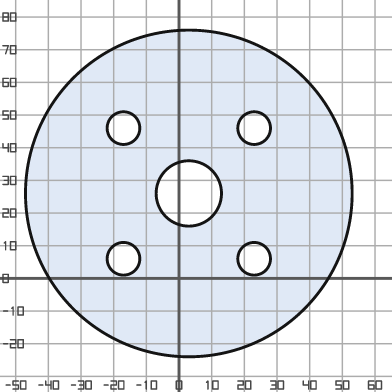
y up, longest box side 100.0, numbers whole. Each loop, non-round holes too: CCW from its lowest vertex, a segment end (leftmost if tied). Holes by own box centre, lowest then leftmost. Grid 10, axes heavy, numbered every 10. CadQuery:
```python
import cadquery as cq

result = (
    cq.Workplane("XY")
    .moveTo(3.0, 26.0)
    .circle(50.0)
    .moveTo(-17.0, 6.0)
    .circle(5.0)
    .moveTo(23.0, 6.0)
    .circle(5.0)
    .moveTo(3.0, 26.0)
    .circle(10.0)
    .moveTo(-17.0, 46.0)
    .circle(5.0)
    .moveTo(23.0, 46.0)
    .circle(5.0)
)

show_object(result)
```